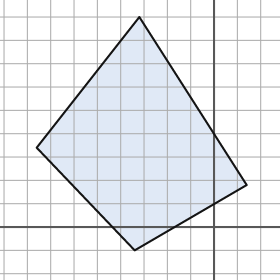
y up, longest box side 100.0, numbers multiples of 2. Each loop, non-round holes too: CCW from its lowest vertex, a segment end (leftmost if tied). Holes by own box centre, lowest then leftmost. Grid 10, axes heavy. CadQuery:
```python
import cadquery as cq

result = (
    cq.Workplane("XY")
    .moveTo(-34.0, -10.0)
    .lineTo(14.0, 18.0)
    .lineTo(-32.0, 90.0)
    .lineTo(-76.0, 34.0)
    .close()
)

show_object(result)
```